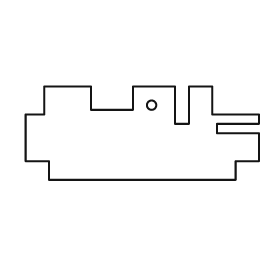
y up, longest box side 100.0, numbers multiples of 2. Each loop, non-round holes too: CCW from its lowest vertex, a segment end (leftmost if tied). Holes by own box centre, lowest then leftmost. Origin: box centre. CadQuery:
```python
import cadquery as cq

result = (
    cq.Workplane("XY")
    .moveTo(-40.0, -20.0)
    .lineTo(40.0, -20.0)
    .lineTo(40.0, -12.0)
    .lineTo(50.0, -12.0)
    .lineTo(50.0, 0.0)
    .lineTo(32.0, 0.0)
    .lineTo(32.0, 4.0)
    .lineTo(50.0, 4.0)
    .lineTo(50.0, 8.0)
    .lineTo(30.0, 8.0)
    .lineTo(30.0, 20.0)
    .lineTo(20.0, 20.0)
    .lineTo(20.0, 4.0)
    .lineTo(14.0, 4.0)
    .lineTo(14.0, 20.0)
    .lineTo(-4.0, 20.0)
    .lineTo(-4.0, 10.0)
    .lineTo(-22.0, 10.0)
    .lineTo(-22.0, 20.0)
    .lineTo(-42.0, 20.0)
    .lineTo(-42.0, 8.0)
    .lineTo(-50.0, 8.0)
    .lineTo(-50.0, -12.0)
    .lineTo(-40.0, -12.0)
    .close()
    .moveTo(4.0, 12.0)
    .circle(2.0)
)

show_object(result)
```